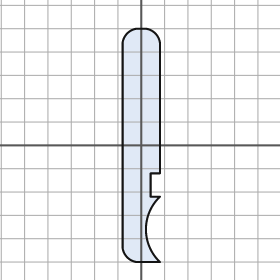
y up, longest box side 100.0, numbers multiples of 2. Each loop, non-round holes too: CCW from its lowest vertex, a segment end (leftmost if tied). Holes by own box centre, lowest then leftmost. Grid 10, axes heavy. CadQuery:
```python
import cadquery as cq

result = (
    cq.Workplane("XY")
    .moveTo(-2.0, -50.0)
    .lineTo(8.0, -50.0)
    .threePointArc((2.0, -36.0), (8.0, -22.0))
    .lineTo(4.0, -22.0)
    .lineTo(4.0, -12.0)
    .lineTo(8.0, -12.0)
    .lineTo(8.0, 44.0)
    .threePointArc((6.0, 48.0), (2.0, 50.0))
    .lineTo(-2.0, 50.0)
    .threePointArc((-6.0, 48.0), (-8.0, 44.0))
    .lineTo(-8.0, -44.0)
    .threePointArc((-6.0, -48.0), (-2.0, -50.0))
    .close()
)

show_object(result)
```